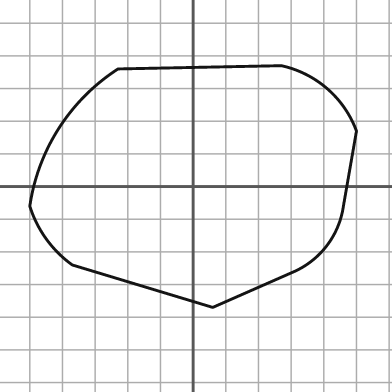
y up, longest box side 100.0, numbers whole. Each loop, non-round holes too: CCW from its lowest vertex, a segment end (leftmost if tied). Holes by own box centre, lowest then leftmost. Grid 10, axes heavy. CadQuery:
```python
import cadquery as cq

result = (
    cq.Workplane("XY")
    .moveTo(6.0, -37.0)
    .lineTo(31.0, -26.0)
    .threePointArc((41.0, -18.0), (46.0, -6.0))
    .lineTo(50.0, 17.0)
    .threePointArc((41.0, 30.0), (27.0, 37.0))
    .lineTo(-23.0, 36.0)
    .threePointArc((-41.0, 18.0), (-50.0, -6.0))
    .threePointArc((-45.0, -16.0), (-37.0, -24.0))
    .close()
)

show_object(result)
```